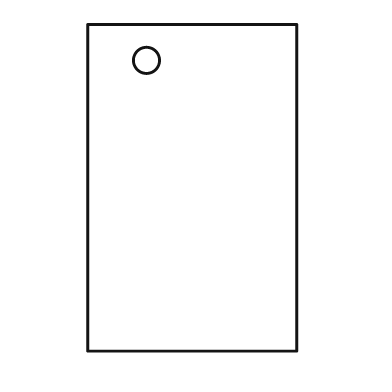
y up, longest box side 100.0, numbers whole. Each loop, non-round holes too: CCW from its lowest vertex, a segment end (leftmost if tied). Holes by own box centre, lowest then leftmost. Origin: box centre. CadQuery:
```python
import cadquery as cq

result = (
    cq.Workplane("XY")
    .moveTo(-32.0, -50.0)
    .lineTo(32.0, -50.0)
    .lineTo(32.0, 50.0)
    .lineTo(-32.0, 50.0)
    .close()
    .moveTo(-14.0, 39.0)
    .circle(4.0)
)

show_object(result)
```